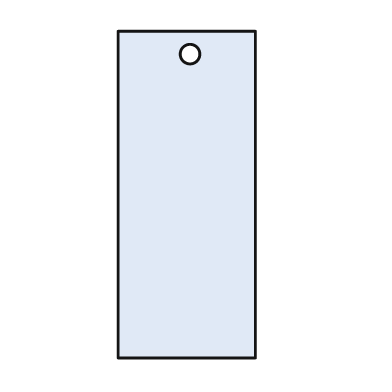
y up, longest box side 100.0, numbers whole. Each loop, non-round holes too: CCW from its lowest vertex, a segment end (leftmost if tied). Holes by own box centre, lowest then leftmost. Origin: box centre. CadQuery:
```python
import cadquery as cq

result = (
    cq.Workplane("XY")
    .moveTo(-21.0, -50.0)
    .lineTo(21.0, -50.0)
    .lineTo(21.0, 50.0)
    .lineTo(-21.0, 50.0)
    .close()
    .moveTo(1.0, 43.0)
    .circle(3.0)
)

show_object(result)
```